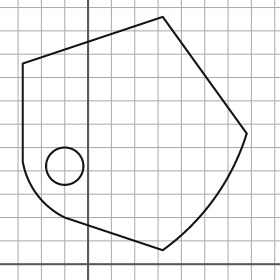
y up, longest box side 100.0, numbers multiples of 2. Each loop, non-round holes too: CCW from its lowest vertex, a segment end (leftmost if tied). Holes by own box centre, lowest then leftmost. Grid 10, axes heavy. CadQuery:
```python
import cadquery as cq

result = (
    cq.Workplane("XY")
    .moveTo(32.0, 6.0)
    .threePointArc((54.0, 28.0), (68.0, 56.0))
    .lineTo(32.0, 106.0)
    .lineTo(-28.0, 86.0)
    .lineTo(-28.0, 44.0)
    .threePointArc((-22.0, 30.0), (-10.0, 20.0))
    .close()
    .moveTo(-10.0, 42.0)
    .circle(8.0)
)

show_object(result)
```